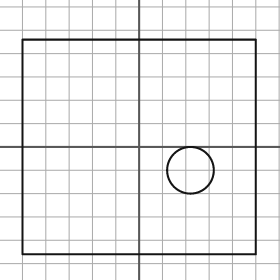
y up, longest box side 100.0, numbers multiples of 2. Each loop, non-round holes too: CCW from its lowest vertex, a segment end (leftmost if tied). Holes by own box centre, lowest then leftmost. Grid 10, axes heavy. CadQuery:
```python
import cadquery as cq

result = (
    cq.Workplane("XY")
    .moveTo(-50.0, -46.0)
    .lineTo(50.0, -46.0)
    .lineTo(50.0, 46.0)
    .lineTo(-50.0, 46.0)
    .close()
    .moveTo(22.0, -10.0)
    .circle(10.0)
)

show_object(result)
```